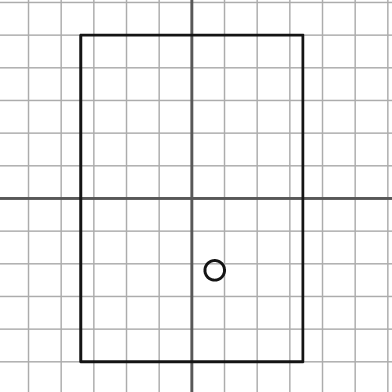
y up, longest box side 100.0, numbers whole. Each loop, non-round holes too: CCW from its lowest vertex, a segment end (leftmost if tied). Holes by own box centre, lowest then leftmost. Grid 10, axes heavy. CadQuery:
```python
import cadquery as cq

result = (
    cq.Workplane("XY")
    .moveTo(-34.0, -50.0)
    .lineTo(34.0, -50.0)
    .lineTo(34.0, 50.0)
    .lineTo(-34.0, 50.0)
    .close()
    .moveTo(7.0, -22.0)
    .circle(3.0)
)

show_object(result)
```